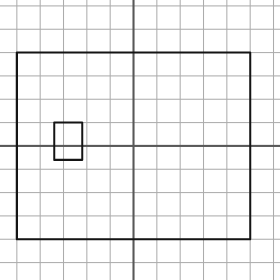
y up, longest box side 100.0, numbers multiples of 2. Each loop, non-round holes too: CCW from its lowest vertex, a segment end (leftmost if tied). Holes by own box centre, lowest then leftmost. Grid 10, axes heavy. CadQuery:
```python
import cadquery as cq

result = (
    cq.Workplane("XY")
    .moveTo(-50.0, -40.0)
    .lineTo(50.0, -40.0)
    .lineTo(50.0, 40.0)
    .lineTo(-50.0, 40.0)
    .close()
    .moveTo(-34.0, -6.0)
    .lineTo(-22.0, -6.0)
    .lineTo(-22.0, 10.0)
    .lineTo(-34.0, 10.0)
    .close()
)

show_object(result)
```